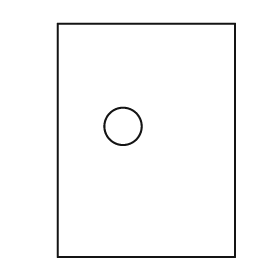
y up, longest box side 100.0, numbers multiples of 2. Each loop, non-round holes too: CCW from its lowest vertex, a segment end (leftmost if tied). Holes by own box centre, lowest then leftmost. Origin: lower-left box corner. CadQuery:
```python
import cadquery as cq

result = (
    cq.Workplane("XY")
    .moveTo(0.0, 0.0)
    .lineTo(76.0, 0.0)
    .lineTo(76.0, 100.0)
    .lineTo(0.0, 100.0)
    .close()
    .moveTo(28.0, 56.0)
    .circle(8.0)
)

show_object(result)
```